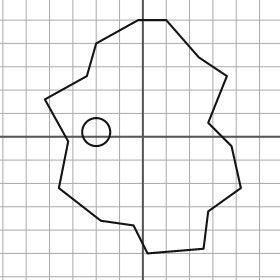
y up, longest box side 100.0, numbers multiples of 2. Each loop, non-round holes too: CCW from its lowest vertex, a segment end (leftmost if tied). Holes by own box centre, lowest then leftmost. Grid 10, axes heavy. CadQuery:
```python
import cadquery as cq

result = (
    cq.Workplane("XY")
    .moveTo(2.0, -50.0)
    .lineTo(26.0, -48.0)
    .lineTo(28.0, -32.0)
    .lineTo(42.0, -22.0)
    .lineTo(38.0, -4.0)
    .lineTo(28.0, 6.0)
    .lineTo(36.0, 26.0)
    .lineTo(24.0, 34.0)
    .lineTo(10.0, 50.0)
    .lineTo(-2.0, 50.0)
    .lineTo(-20.0, 40.0)
    .lineTo(-24.0, 26.0)
    .lineTo(-42.0, 16.0)
    .lineTo(-32.0, -2.0)
    .lineTo(-36.0, -22.0)
    .lineTo(-18.0, -36.0)
    .lineTo(-4.0, -38.0)
    .close()
    .moveTo(-20.0, 2.0)
    .circle(6.0)
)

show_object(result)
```